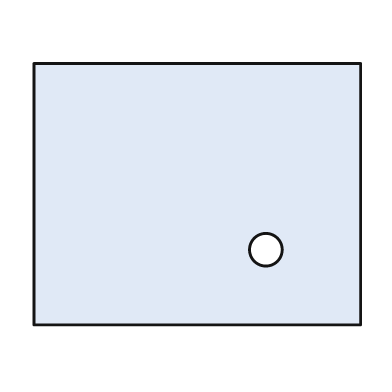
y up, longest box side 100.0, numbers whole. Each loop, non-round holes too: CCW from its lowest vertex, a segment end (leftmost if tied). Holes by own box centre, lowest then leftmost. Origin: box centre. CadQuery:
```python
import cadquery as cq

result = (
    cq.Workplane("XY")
    .moveTo(-50.0, -40.0)
    .lineTo(50.0, -40.0)
    .lineTo(50.0, 40.0)
    .lineTo(-50.0, 40.0)
    .close()
    .moveTo(21.0, -17.0)
    .circle(5.0)
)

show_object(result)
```